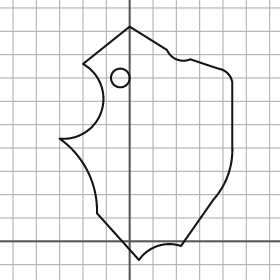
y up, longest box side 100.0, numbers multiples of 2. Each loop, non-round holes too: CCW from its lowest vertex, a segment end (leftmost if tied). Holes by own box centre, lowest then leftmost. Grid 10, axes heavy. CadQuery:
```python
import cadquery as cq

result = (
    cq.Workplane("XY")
    .moveTo(4.0, -8.0)
    .threePointArc((12.0, -2.0), (22.0, -2.0))
    .lineTo(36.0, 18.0)
    .threePointArc((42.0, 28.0), (44.0, 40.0))
    .lineTo(44.0, 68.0)
    .threePointArc((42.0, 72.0), (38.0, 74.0))
    .lineTo(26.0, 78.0)
    .threePointArc((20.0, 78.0), (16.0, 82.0))
    .lineTo(0.0, 92.0)
    .lineTo(-20.0, 76.0)
    .threePointArc((-12.0, 56.0), (-30.0, 44.0))
    .threePointArc((-18.0, 30.0), (-14.0, 12.0))
    .close()
    .moveTo(-4.0, 70.0)
    .circle(4.0)
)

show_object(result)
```